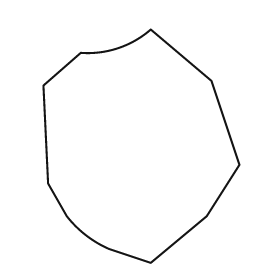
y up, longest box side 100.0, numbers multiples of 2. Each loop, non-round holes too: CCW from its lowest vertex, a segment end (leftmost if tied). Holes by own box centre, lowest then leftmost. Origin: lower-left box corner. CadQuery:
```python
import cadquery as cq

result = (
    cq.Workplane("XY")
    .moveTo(46.0, 0.0)
    .lineTo(70.0, 20.0)
    .lineTo(84.0, 42.0)
    .lineTo(72.0, 78.0)
    .lineTo(46.0, 100.0)
    .threePointArc((32.0, 92.0), (16.0, 90.0))
    .lineTo(0.0, 76.0)
    .lineTo(2.0, 34.0)
    .lineTo(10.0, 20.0)
    .threePointArc((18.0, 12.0), (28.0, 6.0))
    .close()
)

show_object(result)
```